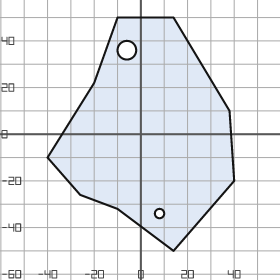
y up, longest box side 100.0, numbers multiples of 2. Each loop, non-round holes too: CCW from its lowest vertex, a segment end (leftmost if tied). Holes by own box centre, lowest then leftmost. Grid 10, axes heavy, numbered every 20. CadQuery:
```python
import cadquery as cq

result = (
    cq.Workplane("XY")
    .moveTo(14.0, -50.0)
    .lineTo(40.0, -20.0)
    .lineTo(38.0, 10.0)
    .lineTo(14.0, 50.0)
    .lineTo(-10.0, 50.0)
    .lineTo(-20.0, 22.0)
    .lineTo(-40.0, -10.0)
    .lineTo(-26.0, -26.0)
    .lineTo(-10.0, -32.0)
    .close()
    .moveTo(8.0, -34.0)
    .circle(2.0)
    .moveTo(-6.0, 36.0)
    .circle(4.0)
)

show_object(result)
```